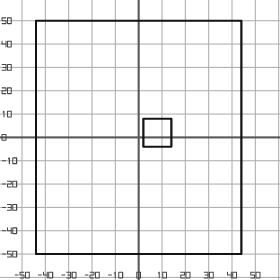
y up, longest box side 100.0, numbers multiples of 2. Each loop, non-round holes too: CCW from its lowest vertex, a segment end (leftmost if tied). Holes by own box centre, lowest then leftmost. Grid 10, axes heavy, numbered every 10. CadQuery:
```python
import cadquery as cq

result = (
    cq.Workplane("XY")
    .moveTo(-44.0, -50.0)
    .lineTo(44.0, -50.0)
    .lineTo(44.0, 50.0)
    .lineTo(-44.0, 50.0)
    .close()
    .moveTo(2.0, -4.0)
    .lineTo(14.0, -4.0)
    .lineTo(14.0, 8.0)
    .lineTo(2.0, 8.0)
    .close()
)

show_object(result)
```